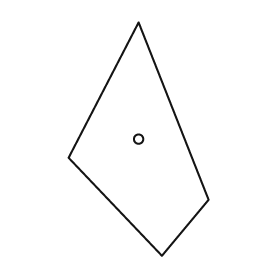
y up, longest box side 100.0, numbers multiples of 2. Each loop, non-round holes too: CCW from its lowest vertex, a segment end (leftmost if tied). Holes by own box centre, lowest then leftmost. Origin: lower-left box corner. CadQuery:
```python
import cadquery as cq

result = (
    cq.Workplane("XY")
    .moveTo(40.0, 0.0)
    .lineTo(60.0, 24.0)
    .lineTo(30.0, 100.0)
    .lineTo(0.0, 42.0)
    .close()
    .moveTo(30.0, 50.0)
    .circle(2.0)
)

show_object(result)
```